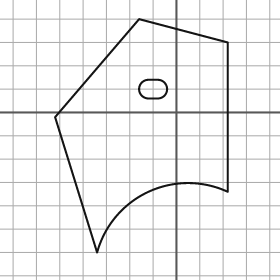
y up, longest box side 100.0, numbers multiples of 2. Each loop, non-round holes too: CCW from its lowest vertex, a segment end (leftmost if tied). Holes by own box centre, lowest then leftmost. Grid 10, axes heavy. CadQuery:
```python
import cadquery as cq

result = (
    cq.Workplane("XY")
    .moveTo(-34.0, -60.0)
    .threePointArc((-12.0, -34.0), (22.0, -34.0))
    .lineTo(22.0, 30.0)
    .lineTo(-16.0, 40.0)
    .lineTo(-52.0, -2.0)
    .close()
    .moveTo(-12.0, 6.0)
    .lineTo(-8.0, 6.0)
    .threePointArc((-4.0, 10.0), (-8.0, 14.0))
    .lineTo(-12.0, 14.0)
    .threePointArc((-16.0, 10.0), (-12.0, 6.0))
    .close()
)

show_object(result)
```